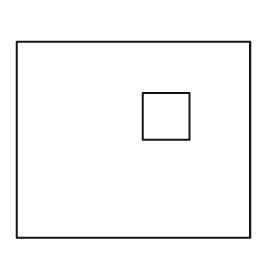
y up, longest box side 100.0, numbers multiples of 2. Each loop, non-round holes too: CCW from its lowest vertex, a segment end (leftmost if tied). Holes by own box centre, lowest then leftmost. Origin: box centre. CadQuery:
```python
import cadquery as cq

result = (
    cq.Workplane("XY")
    .moveTo(-50.0, -42.0)
    .lineTo(50.0, -42.0)
    .lineTo(50.0, 42.0)
    .lineTo(-50.0, 42.0)
    .close()
    .moveTo(4.0, 0.0)
    .lineTo(24.0, 0.0)
    .lineTo(24.0, 20.0)
    .lineTo(4.0, 20.0)
    .close()
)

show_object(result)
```